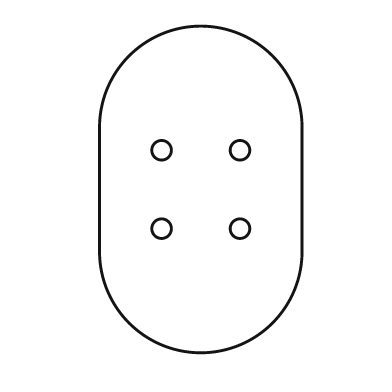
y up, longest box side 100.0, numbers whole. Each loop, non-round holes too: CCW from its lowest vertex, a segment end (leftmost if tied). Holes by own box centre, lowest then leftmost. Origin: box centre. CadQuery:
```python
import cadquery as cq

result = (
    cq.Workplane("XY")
    .moveTo(-31.0, -19.0)
    .threePointArc((0.0, -50.0), (31.0, -19.0))
    .lineTo(31.0, 19.0)
    .threePointArc((0.0, 50.0), (-31.0, 19.0))
    .close()
    .moveTo(-12.0, -12.0)
    .circle(3.0)
    .moveTo(12.0, -12.0)
    .circle(3.0)
    .moveTo(-12.0, 12.0)
    .circle(3.0)
    .moveTo(12.0, 12.0)
    .circle(3.0)
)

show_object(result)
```